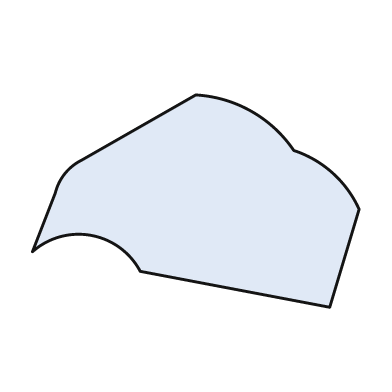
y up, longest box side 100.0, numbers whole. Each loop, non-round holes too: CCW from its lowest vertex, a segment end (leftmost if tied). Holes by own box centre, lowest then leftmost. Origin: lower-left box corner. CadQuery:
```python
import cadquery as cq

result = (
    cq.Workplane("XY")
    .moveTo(91.0, 0.0)
    .lineTo(100.0, 30.0)
    .threePointArc((92.0, 41.0), (80.0, 48.0))
    .threePointArc((67.0, 60.0), (50.0, 65.0))
    .lineTo(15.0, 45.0)
    .threePointArc((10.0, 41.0), (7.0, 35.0))
    .lineTo(0.0, 17.0)
    .threePointArc((18.0, 22.0), (33.0, 11.0))
    .close()
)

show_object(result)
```